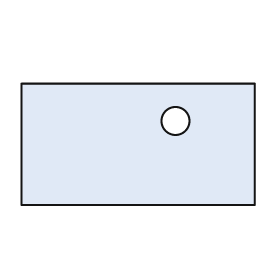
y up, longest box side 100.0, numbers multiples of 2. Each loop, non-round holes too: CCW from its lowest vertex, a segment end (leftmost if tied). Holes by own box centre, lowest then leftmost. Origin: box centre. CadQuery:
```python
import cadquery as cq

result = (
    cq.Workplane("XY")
    .moveTo(-50.0, -26.0)
    .lineTo(50.0, -26.0)
    .lineTo(50.0, 26.0)
    .lineTo(-50.0, 26.0)
    .close()
    .moveTo(16.0, 10.0)
    .circle(6.0)
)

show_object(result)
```